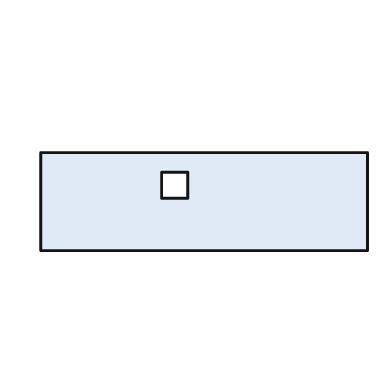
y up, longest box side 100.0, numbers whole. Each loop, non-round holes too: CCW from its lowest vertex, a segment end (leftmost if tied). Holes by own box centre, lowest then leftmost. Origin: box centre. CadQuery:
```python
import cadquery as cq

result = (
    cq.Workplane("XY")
    .moveTo(-50.0, -15.0)
    .lineTo(50.0, -15.0)
    .lineTo(50.0, 15.0)
    .lineTo(-50.0, 15.0)
    .close()
    .moveTo(-13.0, 1.0)
    .lineTo(-5.0, 1.0)
    .lineTo(-5.0, 9.0)
    .lineTo(-13.0, 9.0)
    .close()
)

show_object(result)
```